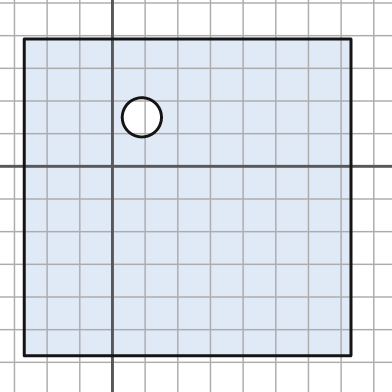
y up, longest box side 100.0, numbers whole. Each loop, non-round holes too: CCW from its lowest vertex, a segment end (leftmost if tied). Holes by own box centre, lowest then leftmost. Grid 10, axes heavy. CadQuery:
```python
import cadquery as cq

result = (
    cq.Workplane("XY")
    .moveTo(-27.0, -58.0)
    .lineTo(73.0, -58.0)
    .lineTo(73.0, 39.0)
    .lineTo(-27.0, 39.0)
    .close()
    .moveTo(9.0, 15.0)
    .circle(6.0)
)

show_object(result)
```